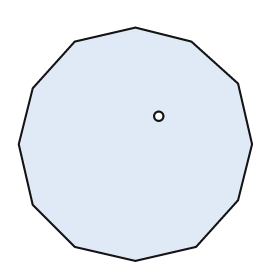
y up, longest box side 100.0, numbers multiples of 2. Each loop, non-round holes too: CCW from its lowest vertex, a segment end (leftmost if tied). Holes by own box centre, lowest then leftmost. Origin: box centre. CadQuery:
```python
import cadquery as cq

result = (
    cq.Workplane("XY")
    .moveTo(0.0, -50.0)
    .lineTo(26.0, -44.0)
    .lineTo(44.0, -24.0)
    .lineTo(50.0, 0.0)
    .lineTo(44.0, 26.0)
    .lineTo(24.0, 44.0)
    .lineTo(0.0, 50.0)
    .lineTo(-26.0, 44.0)
    .lineTo(-44.0, 24.0)
    .lineTo(-50.0, 0.0)
    .lineTo(-44.0, -26.0)
    .lineTo(-26.0, -44.0)
    .close()
    .moveTo(10.0, 12.0)
    .circle(2.0)
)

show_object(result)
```